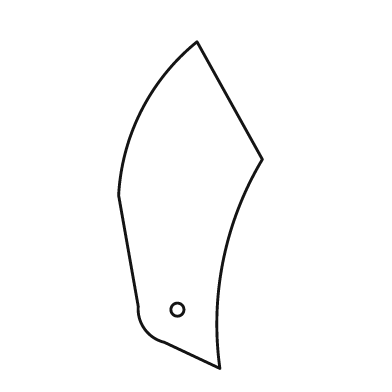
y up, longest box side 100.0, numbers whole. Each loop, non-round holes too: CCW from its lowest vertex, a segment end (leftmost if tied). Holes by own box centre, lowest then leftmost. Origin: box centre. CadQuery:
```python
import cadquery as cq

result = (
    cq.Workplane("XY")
    .moveTo(9.0, -50.0)
    .threePointArc((10.0, -17.0), (22.0, 14.0))
    .lineTo(2.0, 50.0)
    .threePointArc((-15.0, 29.0), (-22.0, 3.0))
    .lineTo(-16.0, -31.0)
    .threePointArc((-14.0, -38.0), (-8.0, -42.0))
    .close()
    .moveTo(-4.0, -32.0)
    .circle(2.0)
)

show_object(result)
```